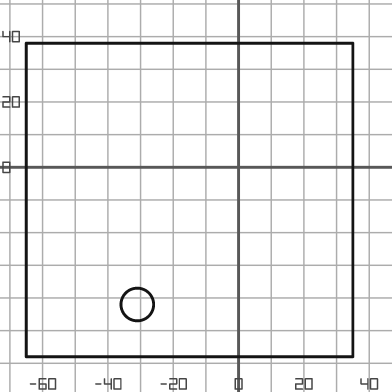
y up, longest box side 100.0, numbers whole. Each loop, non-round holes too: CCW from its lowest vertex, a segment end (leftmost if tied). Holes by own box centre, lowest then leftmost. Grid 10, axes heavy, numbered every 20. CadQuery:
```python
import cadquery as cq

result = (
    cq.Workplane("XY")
    .moveTo(-65.0, -58.0)
    .lineTo(35.0, -58.0)
    .lineTo(35.0, 38.0)
    .lineTo(-65.0, 38.0)
    .close()
    .moveTo(-31.0, -42.0)
    .circle(5.0)
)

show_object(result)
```